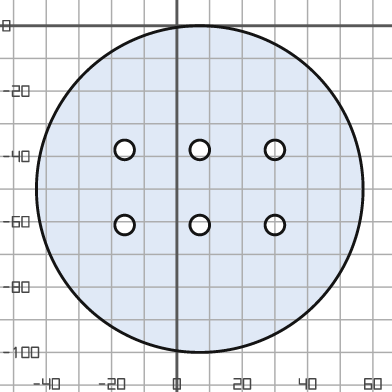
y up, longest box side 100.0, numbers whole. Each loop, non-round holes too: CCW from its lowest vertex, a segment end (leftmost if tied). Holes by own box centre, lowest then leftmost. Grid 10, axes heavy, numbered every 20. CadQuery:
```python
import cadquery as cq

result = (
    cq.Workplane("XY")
    .moveTo(7.0, -50.0)
    .circle(50.0)
    .moveTo(-16.0, -61.0)
    .circle(3.0)
    .moveTo(7.0, -61.0)
    .circle(3.0)
    .moveTo(30.0, -61.0)
    .circle(3.0)
    .moveTo(-16.0, -38.0)
    .circle(3.0)
    .moveTo(7.0, -38.0)
    .circle(3.0)
    .moveTo(30.0, -38.0)
    .circle(3.0)
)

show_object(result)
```